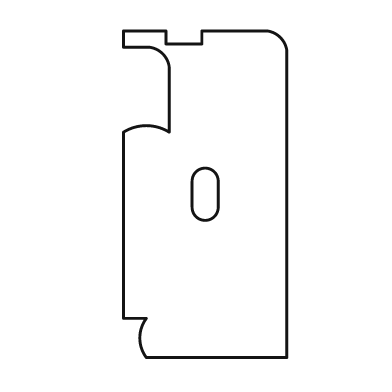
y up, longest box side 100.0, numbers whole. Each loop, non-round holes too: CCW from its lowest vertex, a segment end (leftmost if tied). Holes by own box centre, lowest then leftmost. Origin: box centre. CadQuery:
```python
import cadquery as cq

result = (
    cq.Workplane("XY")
    .moveTo(-18.0, -50.0)
    .lineTo(25.0, -50.0)
    .lineTo(25.0, 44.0)
    .threePointArc((23.0, 48.0), (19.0, 50.0))
    .lineTo(-1.0, 50.0)
    .lineTo(-1.0, 46.0)
    .lineTo(-12.0, 46.0)
    .lineTo(-12.0, 50.0)
    .lineTo(-25.0, 50.0)
    .lineTo(-25.0, 45.0)
    .lineTo(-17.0, 45.0)
    .threePointArc((-13.0, 43.0), (-11.0, 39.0))
    .lineTo(-11.0, 19.0)
    .threePointArc((-18.0, 21.0), (-25.0, 19.0))
    .lineTo(-25.0, -38.0)
    .lineTo(-18.0, -38.0)
    .threePointArc((-20.0, -44.0), (-18.0, -50.0))
    .close()
    .moveTo(-4.0, -4.0)
    .threePointArc((0.0, -8.0), (4.0, -4.0))
    .lineTo(4.0, 4.0)
    .threePointArc((0.0, 8.0), (-4.0, 4.0))
    .close()
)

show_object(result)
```